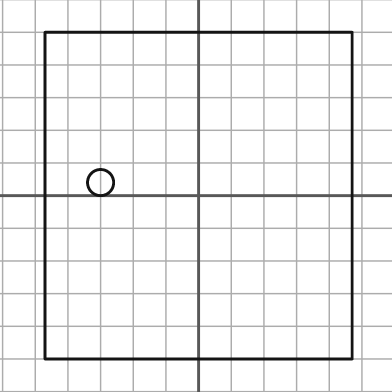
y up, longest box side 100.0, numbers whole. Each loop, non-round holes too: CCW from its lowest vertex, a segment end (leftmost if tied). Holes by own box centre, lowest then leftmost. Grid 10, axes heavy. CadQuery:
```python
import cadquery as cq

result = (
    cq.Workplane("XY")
    .moveTo(-47.0, -50.0)
    .lineTo(47.0, -50.0)
    .lineTo(47.0, 50.0)
    .lineTo(-47.0, 50.0)
    .close()
    .moveTo(-30.0, 4.0)
    .circle(4.0)
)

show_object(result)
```